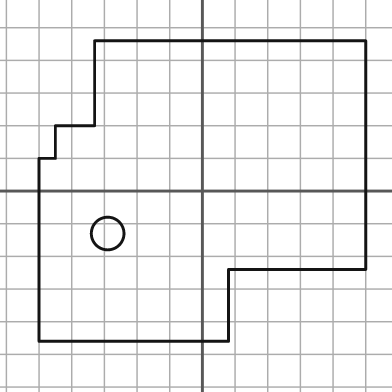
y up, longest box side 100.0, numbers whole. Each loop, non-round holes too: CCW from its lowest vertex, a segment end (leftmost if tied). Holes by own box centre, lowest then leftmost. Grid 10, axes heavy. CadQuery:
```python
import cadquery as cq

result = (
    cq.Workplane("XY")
    .moveTo(-50.0, -46.0)
    .lineTo(8.0, -46.0)
    .lineTo(8.0, -24.0)
    .lineTo(50.0, -24.0)
    .lineTo(50.0, 46.0)
    .lineTo(-33.0, 46.0)
    .lineTo(-33.0, 20.0)
    .lineTo(-45.0, 20.0)
    .lineTo(-45.0, 10.0)
    .lineTo(-50.0, 10.0)
    .close()
    .moveTo(-29.0, -13.0)
    .circle(5.0)
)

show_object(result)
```